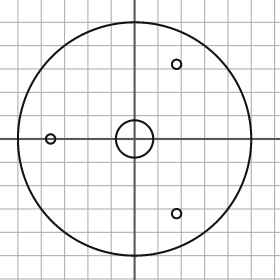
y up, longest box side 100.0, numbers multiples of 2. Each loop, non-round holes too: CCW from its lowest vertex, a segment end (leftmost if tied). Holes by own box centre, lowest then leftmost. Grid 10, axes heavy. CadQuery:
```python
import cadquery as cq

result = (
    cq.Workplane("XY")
    .moveTo(0.0, 0.0)
    .circle(50.0)
    .moveTo(18.0, -32.0)
    .circle(2.0)
    .moveTo(-36.0, 0.0)
    .circle(2.0)
    .moveTo(0.0, 0.0)
    .circle(8.0)
    .moveTo(18.0, 32.0)
    .circle(2.0)
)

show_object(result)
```